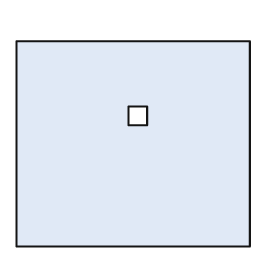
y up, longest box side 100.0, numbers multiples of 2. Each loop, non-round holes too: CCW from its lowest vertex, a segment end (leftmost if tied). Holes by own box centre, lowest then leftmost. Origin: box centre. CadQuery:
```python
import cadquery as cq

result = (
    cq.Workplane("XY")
    .moveTo(-50.0, -44.0)
    .lineTo(50.0, -44.0)
    .lineTo(50.0, 44.0)
    .lineTo(-50.0, 44.0)
    .close()
    .moveTo(-2.0, 8.0)
    .lineTo(6.0, 8.0)
    .lineTo(6.0, 16.0)
    .lineTo(-2.0, 16.0)
    .close()
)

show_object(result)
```